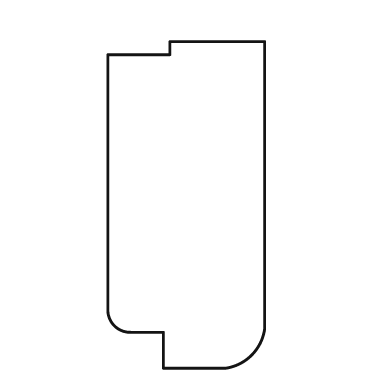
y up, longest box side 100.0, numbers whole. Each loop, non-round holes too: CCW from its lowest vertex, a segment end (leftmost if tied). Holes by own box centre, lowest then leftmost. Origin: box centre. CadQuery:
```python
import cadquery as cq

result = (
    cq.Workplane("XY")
    .moveTo(-7.0, -50.0)
    .lineTo(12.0, -50.0)
    .threePointArc((20.0, -46.0), (24.0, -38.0))
    .lineTo(24.0, 50.0)
    .lineTo(-5.0, 50.0)
    .lineTo(-5.0, 46.0)
    .lineTo(-24.0, 46.0)
    .lineTo(-24.0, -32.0)
    .threePointArc((-22.0, -37.0), (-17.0, -39.0))
    .lineTo(-7.0, -39.0)
    .close()
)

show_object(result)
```